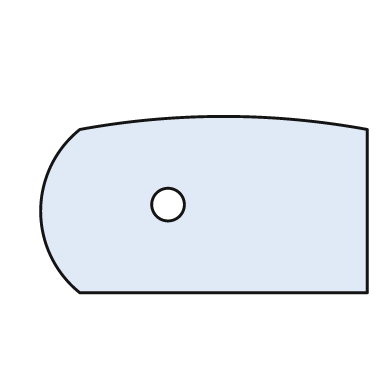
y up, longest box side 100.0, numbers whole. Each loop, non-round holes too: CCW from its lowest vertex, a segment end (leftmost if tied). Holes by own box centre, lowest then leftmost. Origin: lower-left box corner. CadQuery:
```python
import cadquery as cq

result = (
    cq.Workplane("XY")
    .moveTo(12.0, 0.0)
    .lineTo(100.0, 0.0)
    .lineTo(100.0, 50.0)
    .threePointArc((56.0, 54.0), (12.0, 50.0))
    .threePointArc((0.0, 25.0), (12.0, 0.0))
    .close()
    .moveTo(39.0, 27.0)
    .circle(5.0)
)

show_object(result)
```